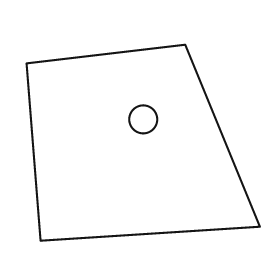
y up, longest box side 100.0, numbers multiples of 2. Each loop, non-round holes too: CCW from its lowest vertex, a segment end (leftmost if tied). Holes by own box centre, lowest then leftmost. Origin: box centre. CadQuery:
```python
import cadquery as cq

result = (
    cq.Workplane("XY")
    .moveTo(-44.0, -42.0)
    .lineTo(50.0, -36.0)
    .lineTo(18.0, 42.0)
    .lineTo(-50.0, 34.0)
    .close()
    .moveTo(0.0, 10.0)
    .circle(6.0)
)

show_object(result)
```